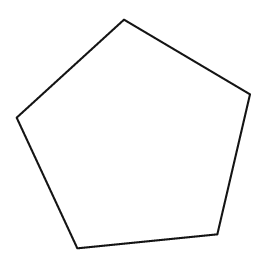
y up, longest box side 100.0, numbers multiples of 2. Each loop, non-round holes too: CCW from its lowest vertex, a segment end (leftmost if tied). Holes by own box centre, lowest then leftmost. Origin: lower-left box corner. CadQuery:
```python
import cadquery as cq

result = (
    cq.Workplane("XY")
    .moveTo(26.0, 0.0)
    .lineTo(86.0, 6.0)
    .lineTo(100.0, 66.0)
    .lineTo(46.0, 98.0)
    .lineTo(0.0, 56.0)
    .close()
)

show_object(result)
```